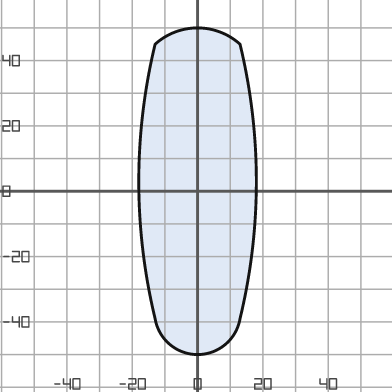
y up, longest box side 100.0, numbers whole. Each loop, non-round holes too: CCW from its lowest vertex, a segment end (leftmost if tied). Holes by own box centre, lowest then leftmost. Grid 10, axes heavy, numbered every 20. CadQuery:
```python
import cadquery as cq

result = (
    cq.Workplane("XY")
    .moveTo(-13.0, -39.0)
    .threePointArc((0.0, -50.0), (13.0, -39.0))
    .threePointArc((18.0, 3.0), (13.0, 45.0))
    .threePointArc((0.0, 50.0), (-13.0, 45.0))
    .threePointArc((-18.0, 3.0), (-13.0, -39.0))
    .close()
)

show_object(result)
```